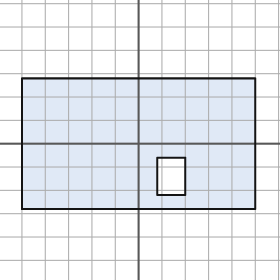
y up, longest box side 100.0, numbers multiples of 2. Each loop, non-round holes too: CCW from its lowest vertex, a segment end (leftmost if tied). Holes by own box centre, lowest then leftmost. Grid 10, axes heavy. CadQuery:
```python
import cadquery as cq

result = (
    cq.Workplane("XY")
    .moveTo(-50.0, -28.0)
    .lineTo(50.0, -28.0)
    .lineTo(50.0, 28.0)
    .lineTo(-50.0, 28.0)
    .close()
    .moveTo(8.0, -22.0)
    .lineTo(20.0, -22.0)
    .lineTo(20.0, -6.0)
    .lineTo(8.0, -6.0)
    .close()
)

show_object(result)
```